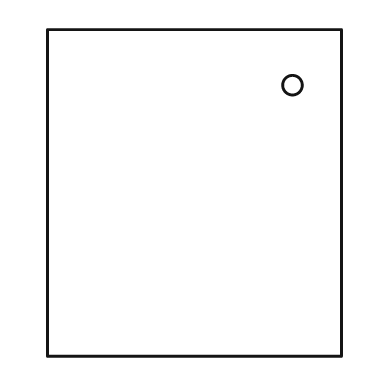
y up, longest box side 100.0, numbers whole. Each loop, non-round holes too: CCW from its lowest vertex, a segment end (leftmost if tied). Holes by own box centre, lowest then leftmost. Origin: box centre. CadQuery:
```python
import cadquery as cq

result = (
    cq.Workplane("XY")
    .moveTo(-45.0, -50.0)
    .lineTo(45.0, -50.0)
    .lineTo(45.0, 50.0)
    .lineTo(-45.0, 50.0)
    .close()
    .moveTo(30.0, 33.0)
    .circle(3.0)
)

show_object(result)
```